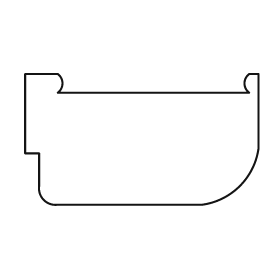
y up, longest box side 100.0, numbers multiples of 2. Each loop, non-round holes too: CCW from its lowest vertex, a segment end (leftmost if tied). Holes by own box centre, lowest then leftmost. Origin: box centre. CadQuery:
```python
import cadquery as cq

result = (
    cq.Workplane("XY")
    .moveTo(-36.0, -28.0)
    .lineTo(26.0, -28.0)
    .threePointArc((42.0, -20.0), (50.0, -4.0))
    .lineTo(50.0, 28.0)
    .lineTo(46.0, 28.0)
    .threePointArc((44.0, 24.0), (46.0, 20.0))
    .lineTo(-36.0, 20.0)
    .threePointArc((-34.0, 24.0), (-36.0, 28.0))
    .lineTo(-50.0, 28.0)
    .lineTo(-50.0, -6.0)
    .lineTo(-44.0, -6.0)
    .lineTo(-44.0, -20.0)
    .threePointArc((-42.0, -26.0), (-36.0, -28.0))
    .close()
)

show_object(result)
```